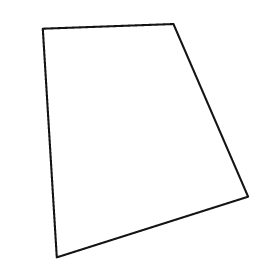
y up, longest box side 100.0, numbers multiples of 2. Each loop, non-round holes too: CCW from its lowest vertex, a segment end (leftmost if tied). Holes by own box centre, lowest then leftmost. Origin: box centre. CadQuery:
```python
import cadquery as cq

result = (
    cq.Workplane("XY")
    .moveTo(-38.0, -50.0)
    .lineTo(44.0, -24.0)
    .lineTo(12.0, 50.0)
    .lineTo(-44.0, 48.0)
    .close()
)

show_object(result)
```